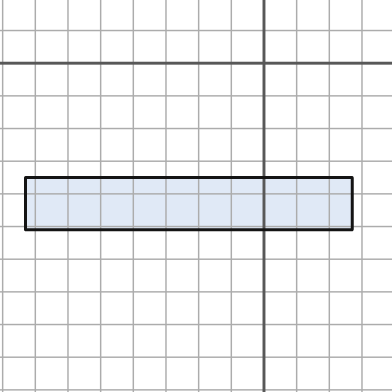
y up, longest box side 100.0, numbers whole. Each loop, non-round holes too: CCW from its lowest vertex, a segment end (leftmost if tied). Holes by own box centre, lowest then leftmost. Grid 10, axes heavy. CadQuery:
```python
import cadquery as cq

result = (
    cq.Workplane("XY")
    .moveTo(-73.0, -51.0)
    .lineTo(27.0, -51.0)
    .lineTo(27.0, -35.0)
    .lineTo(-73.0, -35.0)
    .close()
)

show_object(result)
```